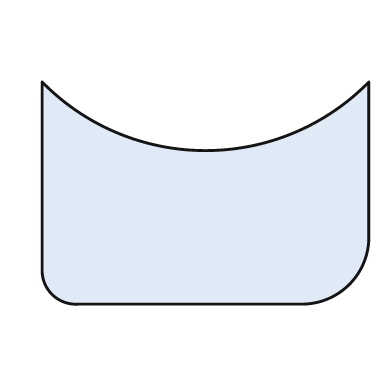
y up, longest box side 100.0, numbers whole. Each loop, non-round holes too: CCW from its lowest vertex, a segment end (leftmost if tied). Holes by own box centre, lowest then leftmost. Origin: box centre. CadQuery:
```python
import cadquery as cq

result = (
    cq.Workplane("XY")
    .moveTo(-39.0, -34.0)
    .lineTo(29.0, -34.0)
    .threePointArc((44.0, -28.0), (50.0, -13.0))
    .lineTo(50.0, 34.0)
    .threePointArc((0.0, 13.0), (-50.0, 34.0))
    .lineTo(-50.0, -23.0)
    .threePointArc((-47.0, -31.0), (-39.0, -34.0))
    .close()
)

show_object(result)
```